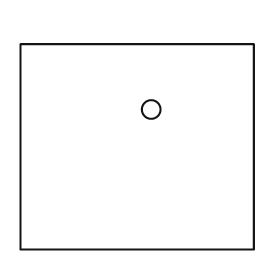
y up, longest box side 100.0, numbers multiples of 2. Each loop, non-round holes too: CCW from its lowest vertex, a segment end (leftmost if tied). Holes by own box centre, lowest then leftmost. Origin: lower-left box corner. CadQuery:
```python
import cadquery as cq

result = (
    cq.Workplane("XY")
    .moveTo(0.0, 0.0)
    .lineTo(100.0, 0.0)
    .lineTo(100.0, 88.0)
    .lineTo(0.0, 88.0)
    .close()
    .moveTo(56.0, 60.0)
    .circle(4.0)
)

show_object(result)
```